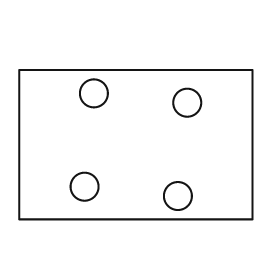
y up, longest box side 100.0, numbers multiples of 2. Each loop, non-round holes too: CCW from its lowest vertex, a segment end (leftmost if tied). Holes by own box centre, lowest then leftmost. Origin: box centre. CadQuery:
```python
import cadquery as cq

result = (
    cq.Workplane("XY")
    .moveTo(-50.0, -32.0)
    .lineTo(50.0, -32.0)
    .lineTo(50.0, 32.0)
    .lineTo(-50.0, 32.0)
    .close()
    .moveTo(18.0, -22.0)
    .circle(6.0)
    .moveTo(-22.0, -18.0)
    .circle(6.0)
    .moveTo(22.0, 18.0)
    .circle(6.0)
    .moveTo(-18.0, 22.0)
    .circle(6.0)
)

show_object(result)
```